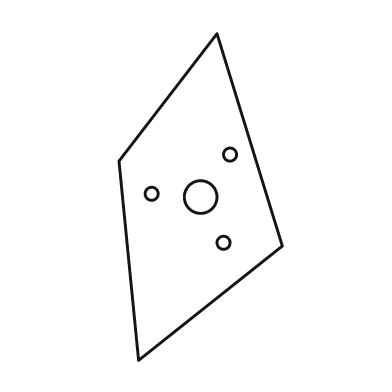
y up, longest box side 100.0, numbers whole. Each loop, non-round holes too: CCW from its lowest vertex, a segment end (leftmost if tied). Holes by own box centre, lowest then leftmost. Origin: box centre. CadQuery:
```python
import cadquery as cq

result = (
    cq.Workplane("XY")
    .moveTo(-19.0, -50.0)
    .lineTo(25.0, -15.0)
    .lineTo(5.0, 50.0)
    .lineTo(-25.0, 11.0)
    .close()
    .moveTo(7.0, -14.0)
    .circle(2.0)
    .moveTo(0.0, 0.0)
    .circle(5.0)
    .moveTo(-15.0, 1.0)
    .circle(2.0)
    .moveTo(9.0, 13.0)
    .circle(2.0)
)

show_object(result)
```